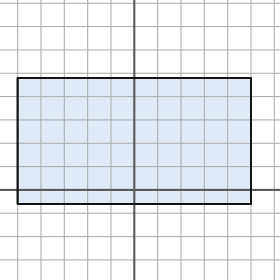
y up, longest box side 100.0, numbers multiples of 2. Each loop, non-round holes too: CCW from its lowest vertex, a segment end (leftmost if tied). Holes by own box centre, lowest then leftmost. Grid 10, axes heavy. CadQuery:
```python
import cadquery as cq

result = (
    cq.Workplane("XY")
    .moveTo(-50.0, -6.0)
    .lineTo(50.0, -6.0)
    .lineTo(50.0, 48.0)
    .lineTo(-50.0, 48.0)
    .close()
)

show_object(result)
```